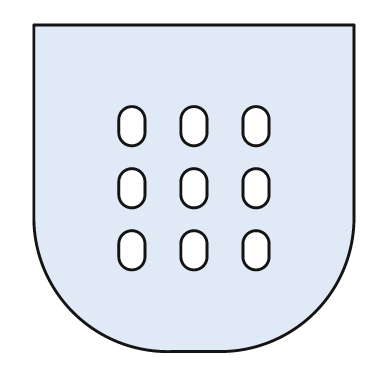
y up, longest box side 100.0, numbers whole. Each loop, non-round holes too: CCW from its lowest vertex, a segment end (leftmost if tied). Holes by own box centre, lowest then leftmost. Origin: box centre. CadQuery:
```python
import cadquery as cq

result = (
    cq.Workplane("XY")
    .moveTo(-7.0, -50.0)
    .lineTo(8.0, -50.0)
    .threePointArc((37.0, -38.0), (49.0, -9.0))
    .lineTo(49.0, 50.0)
    .lineTo(-49.0, 50.0)
    .lineTo(-49.0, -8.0)
    .threePointArc((-37.0, -38.0), (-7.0, -50.0))
    .close()
    .moveTo(-23.0, -21.0)
    .threePointArc((-19.0, -25.0), (-15.0, -21.0))
    .lineTo(-15.0, -17.0)
    .threePointArc((-19.0, -13.0), (-23.0, -17.0))
    .close()
    .moveTo(-4.0, -21.0)
    .threePointArc((0.0, -25.0), (4.0, -21.0))
    .lineTo(4.0, -17.0)
    .threePointArc((0.0, -13.0), (-4.0, -17.0))
    .close()
    .moveTo(15.0, -21.0)
    .threePointArc((19.0, -25.0), (23.0, -21.0))
    .lineTo(23.0, -17.0)
    .threePointArc((19.0, -13.0), (15.0, -17.0))
    .close()
    .moveTo(-23.0, -2.0)
    .threePointArc((-19.0, -6.0), (-15.0, -2.0))
    .lineTo(-15.0, 2.0)
    .threePointArc((-19.0, 6.0), (-23.0, 2.0))
    .close()
    .moveTo(-4.0, -2.0)
    .threePointArc((0.0, -6.0), (4.0, -2.0))
    .lineTo(4.0, 2.0)
    .threePointArc((0.0, 6.0), (-4.0, 2.0))
    .close()
    .moveTo(15.0, -2.0)
    .threePointArc((19.0, -6.0), (23.0, -2.0))
    .lineTo(23.0, 2.0)
    .threePointArc((19.0, 6.0), (15.0, 2.0))
    .close()
    .moveTo(-23.0, 17.0)
    .threePointArc((-19.0, 13.0), (-15.0, 17.0))
    .lineTo(-15.0, 21.0)
    .threePointArc((-19.0, 25.0), (-23.0, 21.0))
    .close()
    .moveTo(-4.0, 17.0)
    .threePointArc((0.0, 13.0), (4.0, 17.0))
    .lineTo(4.0, 21.0)
    .threePointArc((0.0, 25.0), (-4.0, 21.0))
    .close()
    .moveTo(15.0, 17.0)
    .threePointArc((19.0, 13.0), (23.0, 17.0))
    .lineTo(23.0, 21.0)
    .threePointArc((19.0, 25.0), (15.0, 21.0))
    .close()
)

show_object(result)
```